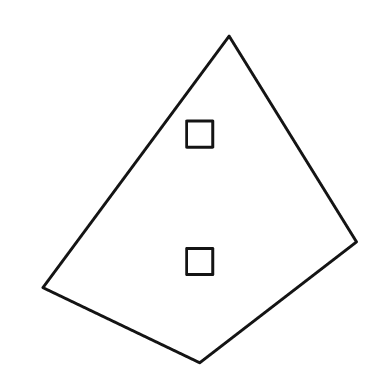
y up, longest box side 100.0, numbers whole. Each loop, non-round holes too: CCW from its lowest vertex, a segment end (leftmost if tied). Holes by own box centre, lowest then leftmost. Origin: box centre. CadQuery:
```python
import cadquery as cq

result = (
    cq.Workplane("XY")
    .moveTo(0.0, -50.0)
    .lineTo(48.0, -13.0)
    .lineTo(9.0, 50.0)
    .lineTo(-48.0, -27.0)
    .close()
    .moveTo(-4.0, -23.0)
    .lineTo(4.0, -23.0)
    .lineTo(4.0, -15.0)
    .lineTo(-4.0, -15.0)
    .close()
    .moveTo(-4.0, 16.0)
    .lineTo(4.0, 16.0)
    .lineTo(4.0, 24.0)
    .lineTo(-4.0, 24.0)
    .close()
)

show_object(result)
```